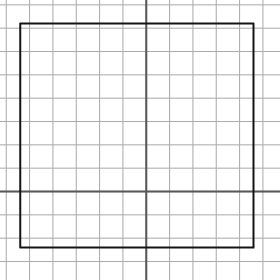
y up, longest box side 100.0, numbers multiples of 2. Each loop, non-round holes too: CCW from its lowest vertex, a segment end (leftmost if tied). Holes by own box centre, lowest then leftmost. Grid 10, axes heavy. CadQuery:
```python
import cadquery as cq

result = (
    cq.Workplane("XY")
    .moveTo(-54.0, -24.0)
    .lineTo(46.0, -24.0)
    .lineTo(46.0, 72.0)
    .lineTo(-54.0, 72.0)
    .close()
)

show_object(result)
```